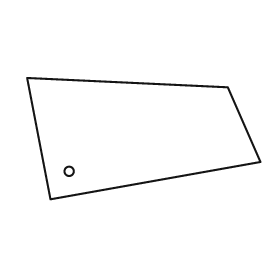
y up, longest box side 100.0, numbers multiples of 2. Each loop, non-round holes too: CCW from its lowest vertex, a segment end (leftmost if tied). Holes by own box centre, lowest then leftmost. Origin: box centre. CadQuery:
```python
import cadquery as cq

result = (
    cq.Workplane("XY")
    .moveTo(-40.0, -26.0)
    .lineTo(50.0, -10.0)
    .lineTo(36.0, 22.0)
    .lineTo(-50.0, 26.0)
    .close()
    .moveTo(-32.0, -14.0)
    .circle(2.0)
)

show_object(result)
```